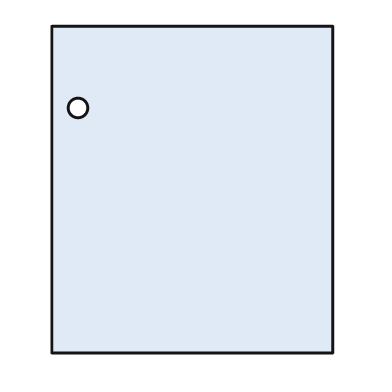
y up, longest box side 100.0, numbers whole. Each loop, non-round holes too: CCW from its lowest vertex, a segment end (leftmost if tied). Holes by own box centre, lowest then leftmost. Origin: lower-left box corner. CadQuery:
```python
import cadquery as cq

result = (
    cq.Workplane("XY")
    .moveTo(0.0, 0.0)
    .lineTo(86.0, 0.0)
    .lineTo(86.0, 100.0)
    .lineTo(0.0, 100.0)
    .close()
    .moveTo(8.0, 75.0)
    .circle(3.0)
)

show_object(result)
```